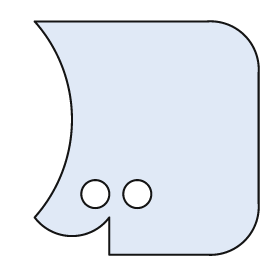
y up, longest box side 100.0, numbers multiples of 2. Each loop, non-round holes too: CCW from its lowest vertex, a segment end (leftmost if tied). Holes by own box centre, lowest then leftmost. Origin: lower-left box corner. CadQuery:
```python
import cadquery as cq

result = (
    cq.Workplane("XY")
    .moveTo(32.0, 0.0)
    .lineTo(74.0, 0.0)
    .threePointArc((90.0, 6.0), (96.0, 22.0))
    .lineTo(96.0, 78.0)
    .threePointArc((90.0, 94.0), (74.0, 100.0))
    .lineTo(0.0, 100.0)
    .threePointArc((16.0, 58.0), (0.0, 16.0))
    .threePointArc((16.0, 8.0), (32.0, 16.0))
    .close()
    .moveTo(26.0, 26.0)
    .circle(6.0)
    .moveTo(44.0, 26.0)
    .circle(6.0)
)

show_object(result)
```